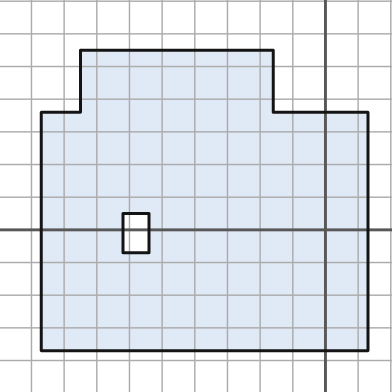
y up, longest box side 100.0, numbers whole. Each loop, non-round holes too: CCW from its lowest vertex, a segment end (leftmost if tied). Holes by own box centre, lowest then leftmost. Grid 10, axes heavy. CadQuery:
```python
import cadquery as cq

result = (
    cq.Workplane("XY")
    .moveTo(-87.0, -37.0)
    .lineTo(13.0, -37.0)
    .lineTo(13.0, 36.0)
    .lineTo(-16.0, 36.0)
    .lineTo(-16.0, 55.0)
    .lineTo(-75.0, 55.0)
    .lineTo(-75.0, 36.0)
    .lineTo(-87.0, 36.0)
    .close()
    .moveTo(-62.0, -7.0)
    .lineTo(-54.0, -7.0)
    .lineTo(-54.0, 5.0)
    .lineTo(-62.0, 5.0)
    .close()
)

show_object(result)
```